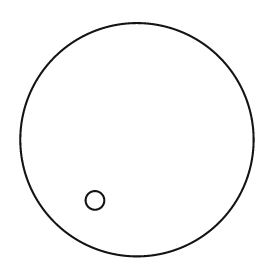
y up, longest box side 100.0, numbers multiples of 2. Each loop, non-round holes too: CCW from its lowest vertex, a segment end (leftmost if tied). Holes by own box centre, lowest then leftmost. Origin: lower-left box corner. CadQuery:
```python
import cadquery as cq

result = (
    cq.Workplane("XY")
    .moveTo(50.0, 50.0)
    .circle(50.0)
    .moveTo(32.0, 24.0)
    .circle(4.0)
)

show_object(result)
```